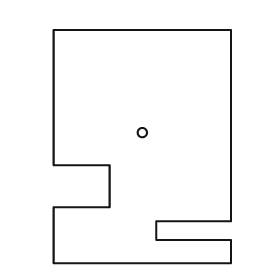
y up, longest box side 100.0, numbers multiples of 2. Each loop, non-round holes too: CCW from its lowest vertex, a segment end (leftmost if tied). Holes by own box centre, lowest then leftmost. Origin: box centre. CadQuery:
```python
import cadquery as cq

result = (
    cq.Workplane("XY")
    .moveTo(-38.0, -50.0)
    .lineTo(38.0, -50.0)
    .lineTo(38.0, -40.0)
    .lineTo(6.0, -40.0)
    .lineTo(6.0, -32.0)
    .lineTo(38.0, -32.0)
    .lineTo(38.0, 50.0)
    .lineTo(-38.0, 50.0)
    .lineTo(-38.0, -8.0)
    .lineTo(-14.0, -8.0)
    .lineTo(-14.0, -26.0)
    .lineTo(-38.0, -26.0)
    .close()
    .moveTo(0.0, 6.0)
    .circle(2.0)
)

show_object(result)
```